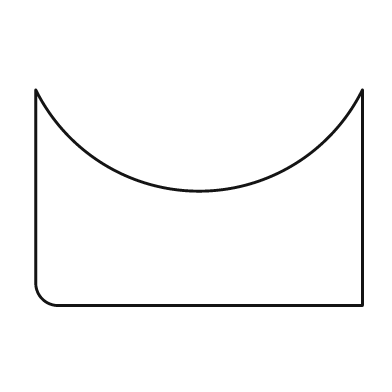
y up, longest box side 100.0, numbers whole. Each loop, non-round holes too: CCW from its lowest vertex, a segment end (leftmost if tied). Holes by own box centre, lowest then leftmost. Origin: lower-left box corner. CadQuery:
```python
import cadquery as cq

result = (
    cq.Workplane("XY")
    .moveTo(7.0, 0.0)
    .lineTo(100.0, 0.0)
    .lineTo(100.0, 66.0)
    .threePointArc((50.0, 35.0), (0.0, 66.0))
    .lineTo(0.0, 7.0)
    .threePointArc((2.0, 2.0), (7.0, 0.0))
    .close()
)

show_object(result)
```